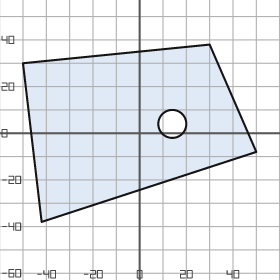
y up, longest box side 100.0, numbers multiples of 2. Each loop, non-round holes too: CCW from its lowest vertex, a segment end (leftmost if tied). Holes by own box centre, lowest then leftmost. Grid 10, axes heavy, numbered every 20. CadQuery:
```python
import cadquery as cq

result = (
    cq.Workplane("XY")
    .moveTo(-42.0, -38.0)
    .lineTo(50.0, -8.0)
    .lineTo(30.0, 38.0)
    .lineTo(-50.0, 30.0)
    .close()
    .moveTo(14.0, 4.0)
    .circle(6.0)
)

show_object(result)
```